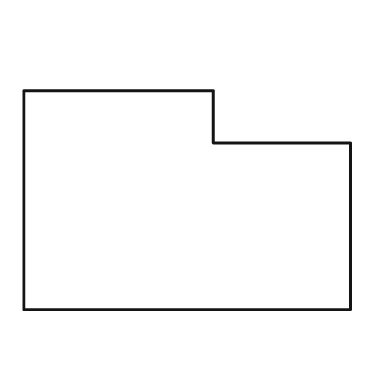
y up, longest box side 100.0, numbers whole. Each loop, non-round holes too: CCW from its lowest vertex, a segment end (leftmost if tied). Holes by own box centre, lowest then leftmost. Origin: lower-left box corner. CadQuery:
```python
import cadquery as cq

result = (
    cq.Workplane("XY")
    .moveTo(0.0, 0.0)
    .lineTo(100.0, 0.0)
    .lineTo(100.0, 51.0)
    .lineTo(58.0, 51.0)
    .lineTo(58.0, 67.0)
    .lineTo(0.0, 67.0)
    .close()
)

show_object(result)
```